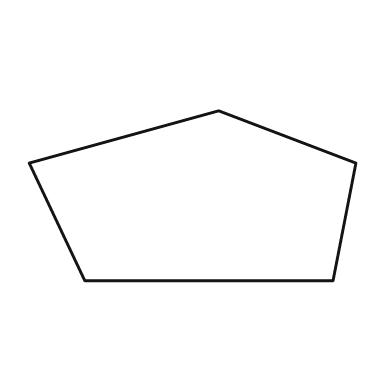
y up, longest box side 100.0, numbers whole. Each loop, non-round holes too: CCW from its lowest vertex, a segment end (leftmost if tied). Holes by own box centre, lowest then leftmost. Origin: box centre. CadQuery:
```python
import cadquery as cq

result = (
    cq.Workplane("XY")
    .moveTo(-33.0, -26.0)
    .lineTo(43.0, -26.0)
    .lineTo(50.0, 10.0)
    .lineTo(8.0, 26.0)
    .lineTo(-50.0, 10.0)
    .close()
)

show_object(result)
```